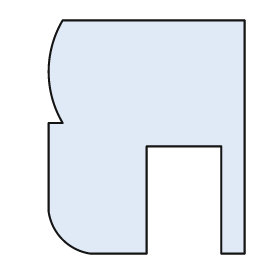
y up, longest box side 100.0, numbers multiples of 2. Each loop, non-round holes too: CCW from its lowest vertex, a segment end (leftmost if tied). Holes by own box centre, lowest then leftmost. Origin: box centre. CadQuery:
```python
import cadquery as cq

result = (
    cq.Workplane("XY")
    .moveTo(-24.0, -50.0)
    .lineTo(0.0, -50.0)
    .lineTo(0.0, -4.0)
    .lineTo(32.0, -4.0)
    .lineTo(32.0, -50.0)
    .lineTo(42.0, -50.0)
    .lineTo(42.0, 50.0)
    .lineTo(-36.0, 50.0)
    .threePointArc((-42.0, 28.0), (-36.0, 6.0))
    .lineTo(-42.0, 6.0)
    .lineTo(-42.0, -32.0)
    .threePointArc((-36.0, -44.0), (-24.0, -50.0))
    .close()
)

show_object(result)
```